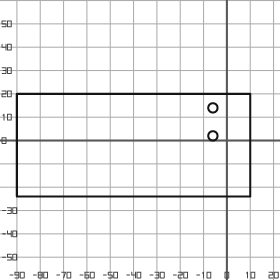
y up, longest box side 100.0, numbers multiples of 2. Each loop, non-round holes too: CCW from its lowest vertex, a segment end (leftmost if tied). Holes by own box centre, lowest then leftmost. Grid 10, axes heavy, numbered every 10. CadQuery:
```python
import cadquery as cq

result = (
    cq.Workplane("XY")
    .moveTo(-90.0, -24.0)
    .lineTo(10.0, -24.0)
    .lineTo(10.0, 20.0)
    .lineTo(-90.0, 20.0)
    .close()
    .moveTo(-6.0, 2.0)
    .circle(2.0)
    .moveTo(-6.0, 14.0)
    .circle(2.0)
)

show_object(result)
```